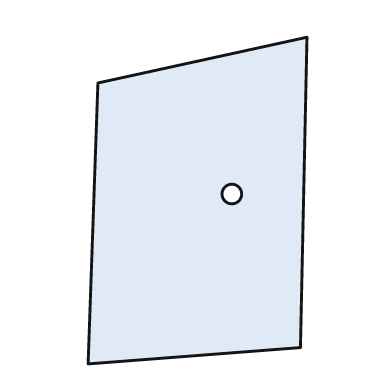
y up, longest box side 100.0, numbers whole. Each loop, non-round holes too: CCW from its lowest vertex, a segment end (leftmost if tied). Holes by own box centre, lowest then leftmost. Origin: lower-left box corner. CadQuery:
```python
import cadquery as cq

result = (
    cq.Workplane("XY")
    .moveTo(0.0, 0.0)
    .lineTo(65.0, 5.0)
    .lineTo(67.0, 100.0)
    .lineTo(3.0, 86.0)
    .close()
    .moveTo(44.0, 52.0)
    .circle(3.0)
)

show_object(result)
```